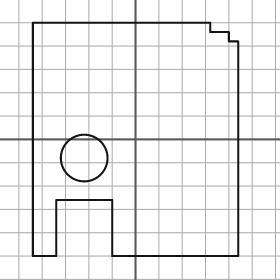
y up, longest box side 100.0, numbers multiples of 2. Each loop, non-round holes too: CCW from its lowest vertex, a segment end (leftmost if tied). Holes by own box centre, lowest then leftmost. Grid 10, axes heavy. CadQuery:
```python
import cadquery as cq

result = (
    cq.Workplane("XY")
    .moveTo(-44.0, -50.0)
    .lineTo(-34.0, -50.0)
    .lineTo(-34.0, -26.0)
    .lineTo(-10.0, -26.0)
    .lineTo(-10.0, -50.0)
    .lineTo(44.0, -50.0)
    .lineTo(44.0, 42.0)
    .lineTo(40.0, 42.0)
    .lineTo(40.0, 46.0)
    .lineTo(32.0, 46.0)
    .lineTo(32.0, 50.0)
    .lineTo(-44.0, 50.0)
    .close()
    .moveTo(-22.0, -8.0)
    .circle(10.0)
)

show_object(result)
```